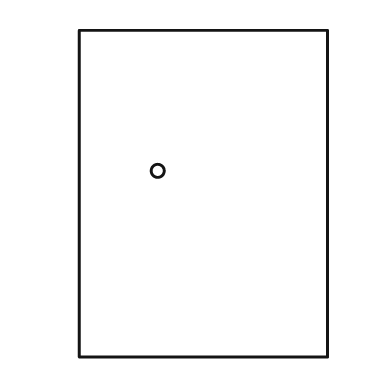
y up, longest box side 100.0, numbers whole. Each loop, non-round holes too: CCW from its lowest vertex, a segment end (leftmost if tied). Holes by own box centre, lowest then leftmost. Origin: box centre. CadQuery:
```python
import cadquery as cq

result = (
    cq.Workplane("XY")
    .moveTo(-38.0, -50.0)
    .lineTo(38.0, -50.0)
    .lineTo(38.0, 50.0)
    .lineTo(-38.0, 50.0)
    .close()
    .moveTo(-14.0, 7.0)
    .circle(2.0)
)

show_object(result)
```